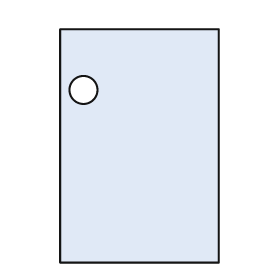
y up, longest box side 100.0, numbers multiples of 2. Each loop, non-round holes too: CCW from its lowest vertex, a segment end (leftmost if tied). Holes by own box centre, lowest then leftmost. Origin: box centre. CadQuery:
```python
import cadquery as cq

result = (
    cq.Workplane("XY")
    .moveTo(-34.0, -50.0)
    .lineTo(34.0, -50.0)
    .lineTo(34.0, 50.0)
    .lineTo(-34.0, 50.0)
    .close()
    .moveTo(-24.0, 24.0)
    .circle(6.0)
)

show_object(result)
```